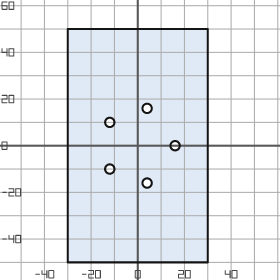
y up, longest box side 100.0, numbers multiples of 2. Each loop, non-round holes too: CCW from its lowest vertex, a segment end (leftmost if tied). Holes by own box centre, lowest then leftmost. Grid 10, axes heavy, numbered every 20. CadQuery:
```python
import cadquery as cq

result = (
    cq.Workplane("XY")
    .moveTo(-30.0, -50.0)
    .lineTo(30.0, -50.0)
    .lineTo(30.0, 50.0)
    .lineTo(-30.0, 50.0)
    .close()
    .moveTo(4.0, -16.0)
    .circle(2.0)
    .moveTo(-12.0, -10.0)
    .circle(2.0)
    .moveTo(16.0, 0.0)
    .circle(2.0)
    .moveTo(-12.0, 10.0)
    .circle(2.0)
    .moveTo(4.0, 16.0)
    .circle(2.0)
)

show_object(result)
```